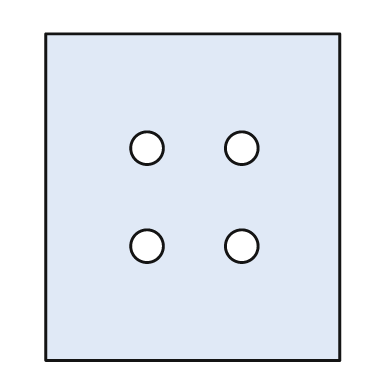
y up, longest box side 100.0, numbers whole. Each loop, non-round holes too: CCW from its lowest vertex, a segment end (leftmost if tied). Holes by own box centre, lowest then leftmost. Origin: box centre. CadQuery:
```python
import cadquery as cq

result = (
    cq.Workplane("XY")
    .moveTo(-45.0, -50.0)
    .lineTo(45.0, -50.0)
    .lineTo(45.0, 50.0)
    .lineTo(-45.0, 50.0)
    .close()
    .moveTo(-14.0, -15.0)
    .circle(5.0)
    .moveTo(15.0, -15.0)
    .circle(5.0)
    .moveTo(-14.0, 15.0)
    .circle(5.0)
    .moveTo(15.0, 15.0)
    .circle(5.0)
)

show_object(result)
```